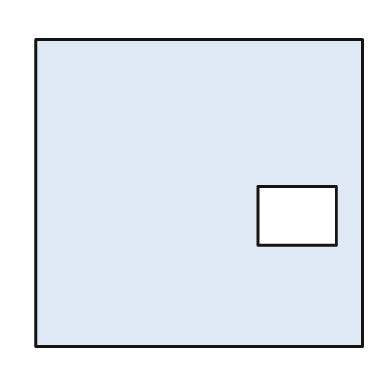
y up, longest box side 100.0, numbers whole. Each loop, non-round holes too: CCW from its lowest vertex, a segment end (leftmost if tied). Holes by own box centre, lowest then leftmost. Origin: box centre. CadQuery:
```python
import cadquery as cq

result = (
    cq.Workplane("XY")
    .moveTo(-50.0, -47.0)
    .lineTo(50.0, -47.0)
    .lineTo(50.0, 47.0)
    .lineTo(-50.0, 47.0)
    .close()
    .moveTo(18.0, -16.0)
    .lineTo(42.0, -16.0)
    .lineTo(42.0, 2.0)
    .lineTo(18.0, 2.0)
    .close()
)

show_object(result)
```